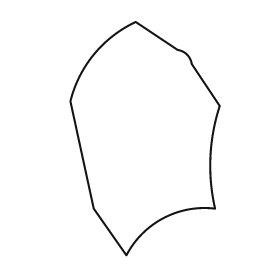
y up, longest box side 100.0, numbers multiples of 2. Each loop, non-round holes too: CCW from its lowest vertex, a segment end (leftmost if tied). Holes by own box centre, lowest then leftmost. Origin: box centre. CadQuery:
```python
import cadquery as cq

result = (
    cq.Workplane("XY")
    .moveTo(-8.0, -50.0)
    .threePointArc((8.0, -34.0), (30.0, -30.0))
    .threePointArc((28.0, -8.0), (32.0, 14.0))
    .lineTo(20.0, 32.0)
    .threePointArc((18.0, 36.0), (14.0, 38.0))
    .lineTo(-4.0, 50.0)
    .threePointArc((-22.0, 36.0), (-32.0, 16.0))
    .lineTo(-22.0, -30.0)
    .close()
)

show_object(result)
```